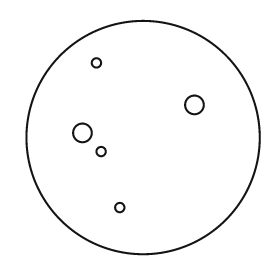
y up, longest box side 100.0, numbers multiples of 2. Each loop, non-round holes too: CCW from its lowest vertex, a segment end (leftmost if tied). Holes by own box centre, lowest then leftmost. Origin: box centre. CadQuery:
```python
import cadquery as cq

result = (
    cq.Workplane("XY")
    .moveTo(0.0, 0.0)
    .circle(50.0)
    .moveTo(-10.0, -30.0)
    .circle(2.0)
    .moveTo(-18.0, -6.0)
    .circle(2.0)
    .moveTo(-26.0, 2.0)
    .circle(4.0)
    .moveTo(22.0, 14.0)
    .circle(4.0)
    .moveTo(-20.0, 32.0)
    .circle(2.0)
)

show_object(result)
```